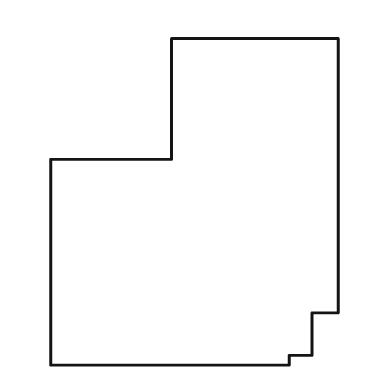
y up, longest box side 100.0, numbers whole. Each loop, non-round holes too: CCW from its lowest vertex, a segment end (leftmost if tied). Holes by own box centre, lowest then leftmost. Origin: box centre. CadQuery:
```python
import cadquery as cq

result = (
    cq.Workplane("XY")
    .moveTo(-44.0, -50.0)
    .lineTo(29.0, -50.0)
    .lineTo(29.0, -47.0)
    .lineTo(36.0, -47.0)
    .lineTo(36.0, -34.0)
    .lineTo(44.0, -34.0)
    .lineTo(44.0, 50.0)
    .lineTo(-7.0, 50.0)
    .lineTo(-7.0, 13.0)
    .lineTo(-44.0, 13.0)
    .close()
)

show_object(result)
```